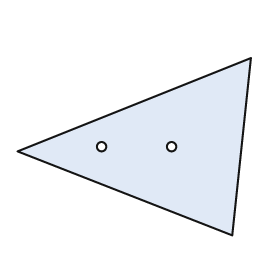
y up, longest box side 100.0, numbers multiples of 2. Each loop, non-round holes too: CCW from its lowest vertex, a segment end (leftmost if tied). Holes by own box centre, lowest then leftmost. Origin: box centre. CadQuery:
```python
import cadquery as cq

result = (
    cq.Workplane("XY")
    .moveTo(42.0, -38.0)
    .lineTo(50.0, 38.0)
    .lineTo(-50.0, -2.0)
    .close()
    .moveTo(-14.0, 0.0)
    .circle(2.0)
    .moveTo(16.0, 0.0)
    .circle(2.0)
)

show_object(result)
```